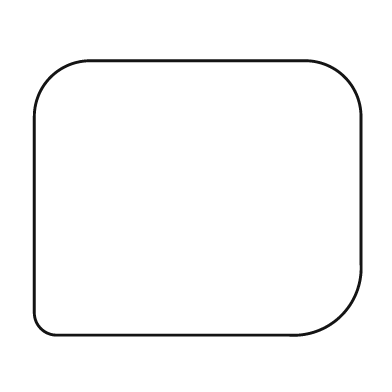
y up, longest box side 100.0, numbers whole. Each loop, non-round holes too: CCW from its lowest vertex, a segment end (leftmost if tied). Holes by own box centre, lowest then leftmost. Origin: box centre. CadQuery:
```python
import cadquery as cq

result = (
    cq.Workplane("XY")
    .moveTo(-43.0, -42.0)
    .lineTo(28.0, -42.0)
    .threePointArc((44.0, -36.0), (50.0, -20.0))
    .lineTo(50.0, 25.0)
    .threePointArc((45.0, 37.0), (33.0, 42.0))
    .lineTo(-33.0, 42.0)
    .threePointArc((-45.0, 37.0), (-50.0, 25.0))
    .lineTo(-50.0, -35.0)
    .threePointArc((-48.0, -40.0), (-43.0, -42.0))
    .close()
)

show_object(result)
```